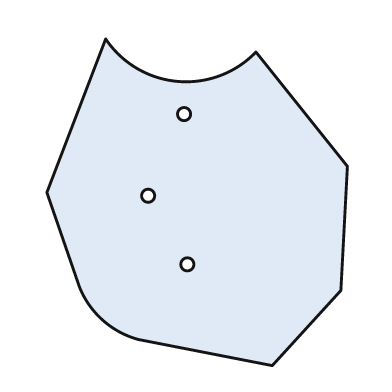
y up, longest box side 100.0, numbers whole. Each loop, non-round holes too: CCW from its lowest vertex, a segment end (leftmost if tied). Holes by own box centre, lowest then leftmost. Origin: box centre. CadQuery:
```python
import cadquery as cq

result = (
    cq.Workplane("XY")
    .moveTo(23.0, -50.0)
    .lineTo(44.0, -27.0)
    .lineTo(46.0, 11.0)
    .lineTo(18.0, 46.0)
    .threePointArc((-6.0, 37.0), (-28.0, 50.0))
    .lineTo(-46.0, 3.0)
    .lineTo(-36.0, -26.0)
    .threePointArc((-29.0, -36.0), (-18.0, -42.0))
    .close()
    .moveTo(-3.0, -19.0)
    .circle(2.0)
    .moveTo(-15.0, 2.0)
    .circle(2.0)
    .moveTo(-4.0, 27.0)
    .circle(2.0)
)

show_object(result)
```